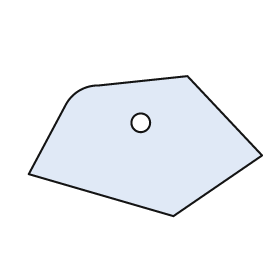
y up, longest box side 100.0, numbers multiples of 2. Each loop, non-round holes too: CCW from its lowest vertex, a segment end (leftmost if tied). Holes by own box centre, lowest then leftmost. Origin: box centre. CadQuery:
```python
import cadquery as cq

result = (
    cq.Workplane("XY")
    .moveTo(12.0, -30.0)
    .lineTo(50.0, -4.0)
    .lineTo(18.0, 30.0)
    .lineTo(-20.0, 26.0)
    .threePointArc((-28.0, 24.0), (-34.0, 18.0))
    .lineTo(-50.0, -12.0)
    .close()
    .moveTo(-2.0, 10.0)
    .circle(4.0)
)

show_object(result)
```